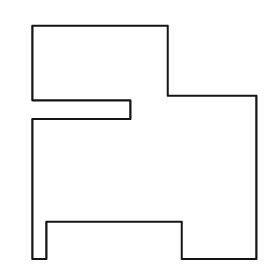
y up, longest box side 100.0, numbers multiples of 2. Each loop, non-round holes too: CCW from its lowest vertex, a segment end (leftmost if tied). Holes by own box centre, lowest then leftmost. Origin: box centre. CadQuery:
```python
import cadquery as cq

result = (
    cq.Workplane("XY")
    .moveTo(-48.0, -50.0)
    .lineTo(-42.0, -50.0)
    .lineTo(-42.0, -34.0)
    .lineTo(16.0, -34.0)
    .lineTo(16.0, -50.0)
    .lineTo(48.0, -50.0)
    .lineTo(48.0, 20.0)
    .lineTo(10.0, 20.0)
    .lineTo(10.0, 50.0)
    .lineTo(-48.0, 50.0)
    .lineTo(-48.0, 18.0)
    .lineTo(-6.0, 18.0)
    .lineTo(-6.0, 10.0)
    .lineTo(-48.0, 10.0)
    .close()
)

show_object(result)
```